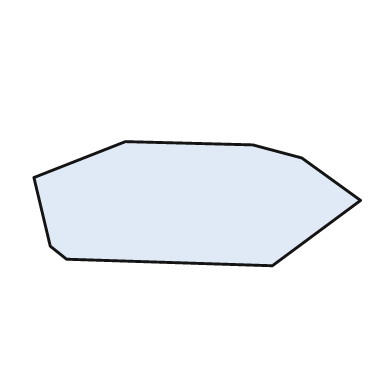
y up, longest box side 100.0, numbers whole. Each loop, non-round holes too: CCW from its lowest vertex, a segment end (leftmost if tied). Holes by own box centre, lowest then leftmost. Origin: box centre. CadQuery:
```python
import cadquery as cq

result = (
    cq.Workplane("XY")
    .moveTo(23.0, -19.0)
    .lineTo(50.0, 1.0)
    .lineTo(32.0, 14.0)
    .lineTo(17.0, 18.0)
    .lineTo(-22.0, 19.0)
    .lineTo(-50.0, 8.0)
    .lineTo(-45.0, -13.0)
    .lineTo(-40.0, -17.0)
    .close()
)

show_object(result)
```